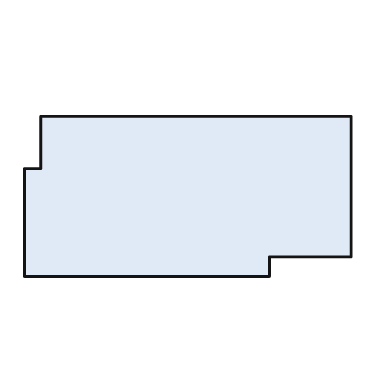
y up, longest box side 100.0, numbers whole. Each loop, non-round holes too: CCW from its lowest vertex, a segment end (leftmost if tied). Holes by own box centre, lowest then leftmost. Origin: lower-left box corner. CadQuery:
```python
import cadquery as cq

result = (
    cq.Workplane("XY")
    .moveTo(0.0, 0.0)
    .lineTo(75.0, 0.0)
    .lineTo(75.0, 6.0)
    .lineTo(100.0, 6.0)
    .lineTo(100.0, 49.0)
    .lineTo(5.0, 49.0)
    .lineTo(5.0, 33.0)
    .lineTo(0.0, 33.0)
    .close()
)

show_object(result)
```